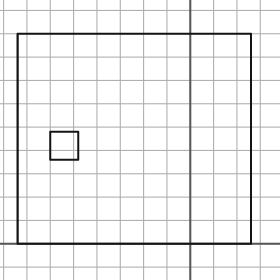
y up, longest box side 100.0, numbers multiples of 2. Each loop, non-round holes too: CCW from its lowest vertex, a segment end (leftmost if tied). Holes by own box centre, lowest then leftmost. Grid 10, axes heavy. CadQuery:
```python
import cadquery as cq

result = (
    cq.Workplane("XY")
    .moveTo(-74.0, 0.0)
    .lineTo(26.0, 0.0)
    .lineTo(26.0, 90.0)
    .lineTo(-74.0, 90.0)
    .close()
    .moveTo(-60.0, 36.0)
    .lineTo(-48.0, 36.0)
    .lineTo(-48.0, 48.0)
    .lineTo(-60.0, 48.0)
    .close()
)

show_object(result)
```